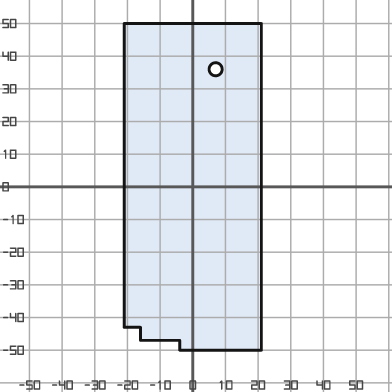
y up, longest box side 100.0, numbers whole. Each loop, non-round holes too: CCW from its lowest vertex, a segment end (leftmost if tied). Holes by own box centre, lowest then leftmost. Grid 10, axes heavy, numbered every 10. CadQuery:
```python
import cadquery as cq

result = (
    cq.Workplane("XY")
    .moveTo(-4.0, -50.0)
    .lineTo(21.0, -50.0)
    .lineTo(21.0, 50.0)
    .lineTo(-21.0, 50.0)
    .lineTo(-21.0, -43.0)
    .lineTo(-16.0, -43.0)
    .lineTo(-16.0, -47.0)
    .lineTo(-4.0, -47.0)
    .close()
    .moveTo(7.0, 36.0)
    .circle(2.0)
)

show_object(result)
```